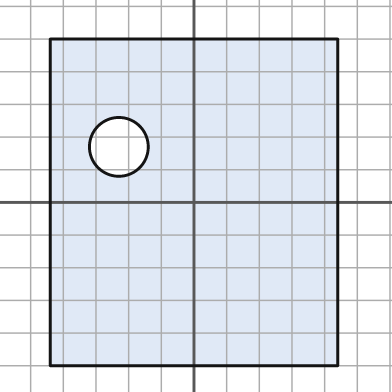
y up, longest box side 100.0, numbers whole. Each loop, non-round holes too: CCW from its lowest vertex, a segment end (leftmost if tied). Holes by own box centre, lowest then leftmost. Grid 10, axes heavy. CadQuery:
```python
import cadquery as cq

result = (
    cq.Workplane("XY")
    .moveTo(-44.0, -50.0)
    .lineTo(44.0, -50.0)
    .lineTo(44.0, 50.0)
    .lineTo(-44.0, 50.0)
    .close()
    .moveTo(-23.0, 17.0)
    .circle(9.0)
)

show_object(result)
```